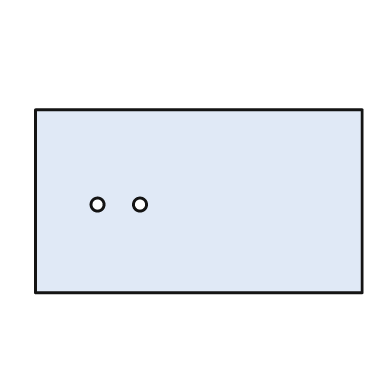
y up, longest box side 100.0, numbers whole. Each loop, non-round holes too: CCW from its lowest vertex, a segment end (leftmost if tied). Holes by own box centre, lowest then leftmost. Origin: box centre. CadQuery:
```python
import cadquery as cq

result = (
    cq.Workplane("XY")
    .moveTo(-50.0, -28.0)
    .lineTo(50.0, -28.0)
    .lineTo(50.0, 28.0)
    .lineTo(-50.0, 28.0)
    .close()
    .moveTo(-31.0, -1.0)
    .circle(2.0)
    .moveTo(-18.0, -1.0)
    .circle(2.0)
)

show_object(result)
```